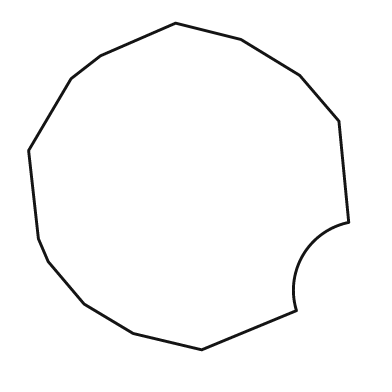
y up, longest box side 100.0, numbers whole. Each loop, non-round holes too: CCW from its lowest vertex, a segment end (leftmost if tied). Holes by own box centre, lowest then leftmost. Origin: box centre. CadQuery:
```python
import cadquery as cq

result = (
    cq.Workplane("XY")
    .moveTo(4.0, -50.0)
    .lineTo(33.0, -38.0)
    .threePointArc((35.0, -21.0), (49.0, -11.0))
    .lineTo(46.0, 20.0)
    .lineTo(34.0, 34.0)
    .lineTo(16.0, 45.0)
    .lineTo(-4.0, 50.0)
    .lineTo(-27.0, 40.0)
    .lineTo(-36.0, 33.0)
    .lineTo(-49.0, 11.0)
    .lineTo(-46.0, -16.0)
    .lineTo(-43.0, -23.0)
    .lineTo(-32.0, -36.0)
    .lineTo(-17.0, -45.0)
    .close()
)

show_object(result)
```